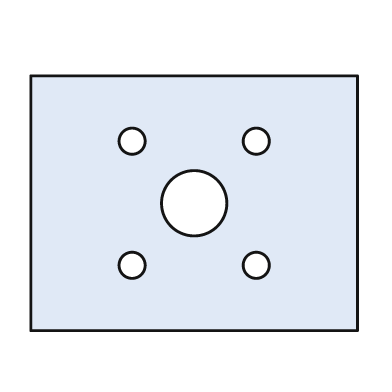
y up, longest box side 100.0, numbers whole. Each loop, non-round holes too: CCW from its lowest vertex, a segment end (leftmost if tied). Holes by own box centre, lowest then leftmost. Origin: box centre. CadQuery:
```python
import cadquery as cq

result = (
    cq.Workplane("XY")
    .moveTo(-50.0, -39.0)
    .lineTo(50.0, -39.0)
    .lineTo(50.0, 39.0)
    .lineTo(-50.0, 39.0)
    .close()
    .moveTo(-19.0, -19.0)
    .circle(4.0)
    .moveTo(19.0, -19.0)
    .circle(4.0)
    .moveTo(0.0, 0.0)
    .circle(10.0)
    .moveTo(-19.0, 19.0)
    .circle(4.0)
    .moveTo(19.0, 19.0)
    .circle(4.0)
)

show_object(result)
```